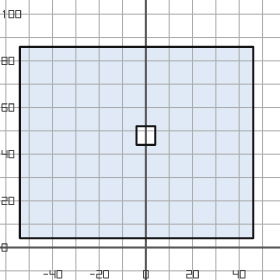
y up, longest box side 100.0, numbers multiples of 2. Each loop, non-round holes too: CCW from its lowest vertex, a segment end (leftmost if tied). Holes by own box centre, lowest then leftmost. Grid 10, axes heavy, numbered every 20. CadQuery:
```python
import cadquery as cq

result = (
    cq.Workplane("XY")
    .moveTo(-54.0, 4.0)
    .lineTo(46.0, 4.0)
    .lineTo(46.0, 86.0)
    .lineTo(-54.0, 86.0)
    .close()
    .moveTo(-4.0, 44.0)
    .lineTo(4.0, 44.0)
    .lineTo(4.0, 52.0)
    .lineTo(-4.0, 52.0)
    .close()
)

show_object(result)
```